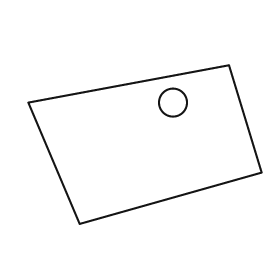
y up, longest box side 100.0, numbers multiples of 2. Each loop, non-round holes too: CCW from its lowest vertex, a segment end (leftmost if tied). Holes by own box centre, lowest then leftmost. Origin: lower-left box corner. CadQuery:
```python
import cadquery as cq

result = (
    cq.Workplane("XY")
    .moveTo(22.0, 0.0)
    .lineTo(100.0, 22.0)
    .lineTo(86.0, 68.0)
    .lineTo(0.0, 52.0)
    .close()
    .moveTo(62.0, 52.0)
    .circle(6.0)
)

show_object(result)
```